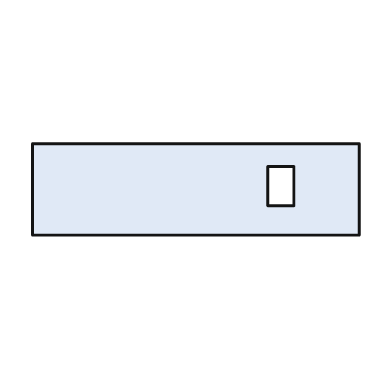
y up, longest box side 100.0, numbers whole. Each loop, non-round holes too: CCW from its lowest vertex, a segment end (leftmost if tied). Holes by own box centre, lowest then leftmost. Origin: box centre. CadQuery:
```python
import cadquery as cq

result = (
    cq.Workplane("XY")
    .moveTo(-50.0, -14.0)
    .lineTo(50.0, -14.0)
    .lineTo(50.0, 14.0)
    .lineTo(-50.0, 14.0)
    .close()
    .moveTo(22.0, -5.0)
    .lineTo(30.0, -5.0)
    .lineTo(30.0, 7.0)
    .lineTo(22.0, 7.0)
    .close()
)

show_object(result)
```